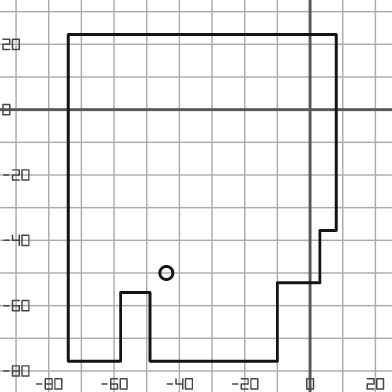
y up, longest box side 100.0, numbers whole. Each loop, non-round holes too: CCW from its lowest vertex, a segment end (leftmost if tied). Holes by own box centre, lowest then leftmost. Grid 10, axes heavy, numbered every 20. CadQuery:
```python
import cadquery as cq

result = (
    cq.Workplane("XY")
    .moveTo(-74.0, -77.0)
    .lineTo(-58.0, -77.0)
    .lineTo(-58.0, -56.0)
    .lineTo(-49.0, -56.0)
    .lineTo(-49.0, -77.0)
    .lineTo(-10.0, -77.0)
    .lineTo(-10.0, -53.0)
    .lineTo(3.0, -53.0)
    .lineTo(3.0, -37.0)
    .lineTo(8.0, -37.0)
    .lineTo(8.0, 23.0)
    .lineTo(-74.0, 23.0)
    .close()
    .moveTo(-44.0, -50.0)
    .circle(2.0)
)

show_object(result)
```